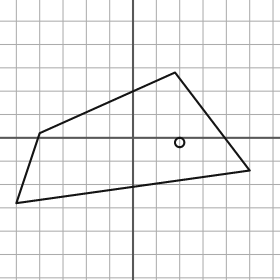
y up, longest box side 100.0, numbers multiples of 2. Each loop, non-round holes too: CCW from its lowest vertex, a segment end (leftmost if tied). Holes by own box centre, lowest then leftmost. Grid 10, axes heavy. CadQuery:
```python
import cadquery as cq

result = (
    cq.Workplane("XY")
    .moveTo(-50.0, -28.0)
    .lineTo(50.0, -14.0)
    .lineTo(18.0, 28.0)
    .lineTo(-40.0, 2.0)
    .close()
    .moveTo(20.0, -2.0)
    .circle(2.0)
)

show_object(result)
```